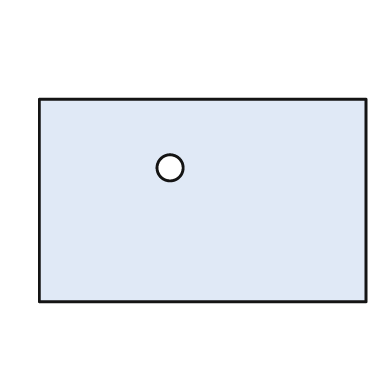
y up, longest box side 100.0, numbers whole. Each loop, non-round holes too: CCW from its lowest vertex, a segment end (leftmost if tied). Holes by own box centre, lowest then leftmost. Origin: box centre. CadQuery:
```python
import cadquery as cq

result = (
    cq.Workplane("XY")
    .moveTo(-50.0, -31.0)
    .lineTo(50.0, -31.0)
    .lineTo(50.0, 31.0)
    .lineTo(-50.0, 31.0)
    .close()
    .moveTo(-10.0, 10.0)
    .circle(4.0)
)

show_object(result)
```